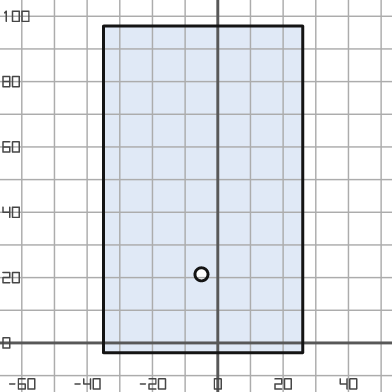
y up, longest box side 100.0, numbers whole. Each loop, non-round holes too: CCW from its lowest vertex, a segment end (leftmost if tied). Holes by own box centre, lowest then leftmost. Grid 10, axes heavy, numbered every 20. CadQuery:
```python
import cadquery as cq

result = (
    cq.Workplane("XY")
    .moveTo(-35.0, -3.0)
    .lineTo(26.0, -3.0)
    .lineTo(26.0, 97.0)
    .lineTo(-35.0, 97.0)
    .close()
    .moveTo(-5.0, 21.0)
    .circle(2.0)
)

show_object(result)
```